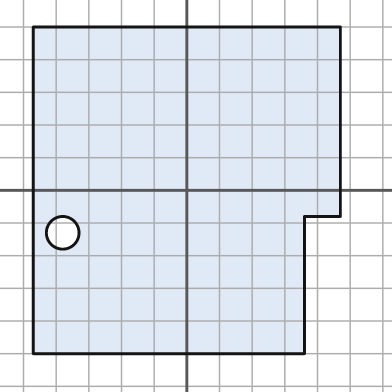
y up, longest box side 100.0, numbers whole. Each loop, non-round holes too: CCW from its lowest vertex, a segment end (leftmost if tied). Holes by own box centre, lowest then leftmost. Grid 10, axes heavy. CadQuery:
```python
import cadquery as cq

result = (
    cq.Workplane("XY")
    .moveTo(-47.0, -50.0)
    .lineTo(36.0, -50.0)
    .lineTo(36.0, -8.0)
    .lineTo(47.0, -8.0)
    .lineTo(47.0, 50.0)
    .lineTo(-47.0, 50.0)
    .close()
    .moveTo(-38.0, -13.0)
    .circle(5.0)
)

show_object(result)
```